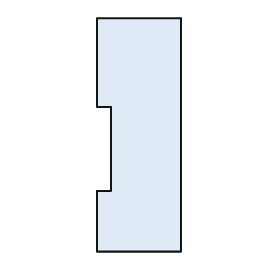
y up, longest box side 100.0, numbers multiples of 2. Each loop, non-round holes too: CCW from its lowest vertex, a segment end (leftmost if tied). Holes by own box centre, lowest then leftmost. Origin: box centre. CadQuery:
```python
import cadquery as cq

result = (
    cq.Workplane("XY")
    .moveTo(-18.0, -50.0)
    .lineTo(18.0, -50.0)
    .lineTo(18.0, 50.0)
    .lineTo(-18.0, 50.0)
    .lineTo(-18.0, 12.0)
    .lineTo(-12.0, 12.0)
    .lineTo(-12.0, -24.0)
    .lineTo(-18.0, -24.0)
    .close()
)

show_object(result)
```